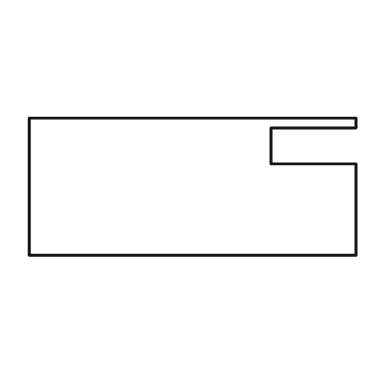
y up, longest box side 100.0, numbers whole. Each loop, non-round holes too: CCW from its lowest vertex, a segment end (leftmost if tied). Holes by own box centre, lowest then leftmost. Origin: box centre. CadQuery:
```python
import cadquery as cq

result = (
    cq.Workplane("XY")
    .moveTo(-50.0, -21.0)
    .lineTo(50.0, -21.0)
    .lineTo(50.0, 7.0)
    .lineTo(24.0, 7.0)
    .lineTo(24.0, 18.0)
    .lineTo(50.0, 18.0)
    .lineTo(50.0, 21.0)
    .lineTo(-50.0, 21.0)
    .close()
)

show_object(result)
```